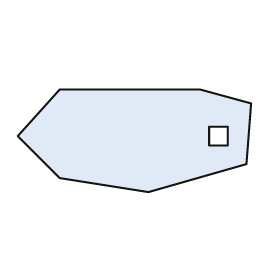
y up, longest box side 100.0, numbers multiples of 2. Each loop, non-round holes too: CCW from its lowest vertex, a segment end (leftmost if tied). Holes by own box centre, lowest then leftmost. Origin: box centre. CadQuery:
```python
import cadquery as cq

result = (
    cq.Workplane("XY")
    .moveTo(6.0, -22.0)
    .lineTo(48.0, -10.0)
    .lineTo(50.0, 16.0)
    .lineTo(28.0, 22.0)
    .lineTo(-32.0, 22.0)
    .lineTo(-50.0, 2.0)
    .lineTo(-32.0, -16.0)
    .close()
    .moveTo(32.0, -2.0)
    .lineTo(40.0, -2.0)
    .lineTo(40.0, 6.0)
    .lineTo(32.0, 6.0)
    .close()
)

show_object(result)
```